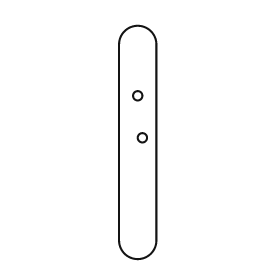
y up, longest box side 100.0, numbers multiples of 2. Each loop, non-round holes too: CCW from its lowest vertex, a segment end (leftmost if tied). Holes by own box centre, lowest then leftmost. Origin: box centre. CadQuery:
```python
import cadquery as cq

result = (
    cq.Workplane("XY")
    .moveTo(-8.0, -42.0)
    .threePointArc((0.0, -50.0), (8.0, -42.0))
    .lineTo(8.0, 42.0)
    .threePointArc((0.0, 50.0), (-8.0, 42.0))
    .close()
    .moveTo(2.0, 2.0)
    .circle(2.0)
    .moveTo(0.0, 20.0)
    .circle(2.0)
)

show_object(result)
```